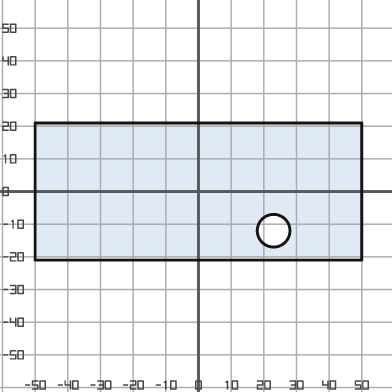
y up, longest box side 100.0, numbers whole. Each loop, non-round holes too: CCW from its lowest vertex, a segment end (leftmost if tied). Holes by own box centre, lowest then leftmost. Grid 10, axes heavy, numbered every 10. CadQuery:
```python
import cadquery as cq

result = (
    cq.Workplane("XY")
    .moveTo(-50.0, -21.0)
    .lineTo(50.0, -21.0)
    .lineTo(50.0, 21.0)
    .lineTo(-50.0, 21.0)
    .close()
    .moveTo(23.0, -12.0)
    .circle(5.0)
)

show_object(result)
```